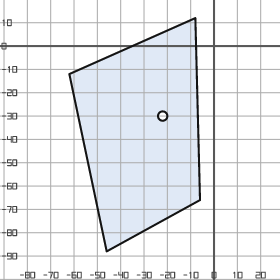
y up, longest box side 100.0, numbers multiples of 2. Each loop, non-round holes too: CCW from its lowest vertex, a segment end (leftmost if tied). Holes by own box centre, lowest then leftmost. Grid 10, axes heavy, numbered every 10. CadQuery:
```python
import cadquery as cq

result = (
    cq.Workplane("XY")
    .moveTo(-46.0, -88.0)
    .lineTo(-6.0, -66.0)
    .lineTo(-8.0, 12.0)
    .lineTo(-62.0, -12.0)
    .close()
    .moveTo(-22.0, -30.0)
    .circle(2.0)
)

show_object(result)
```